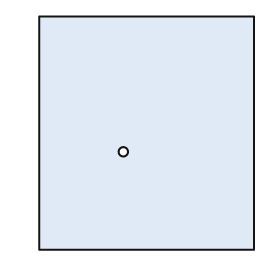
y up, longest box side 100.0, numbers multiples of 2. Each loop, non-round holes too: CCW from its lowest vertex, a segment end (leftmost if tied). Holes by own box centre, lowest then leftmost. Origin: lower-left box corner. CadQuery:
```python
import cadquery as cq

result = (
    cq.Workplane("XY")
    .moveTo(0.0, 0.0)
    .lineTo(92.0, 0.0)
    .lineTo(92.0, 100.0)
    .lineTo(0.0, 100.0)
    .close()
    .moveTo(36.0, 42.0)
    .circle(2.0)
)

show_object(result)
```